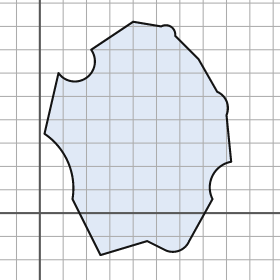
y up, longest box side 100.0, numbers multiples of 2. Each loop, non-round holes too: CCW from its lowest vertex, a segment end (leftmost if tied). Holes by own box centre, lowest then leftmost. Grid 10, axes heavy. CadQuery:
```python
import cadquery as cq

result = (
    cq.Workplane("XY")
    .moveTo(26.0, -18.0)
    .lineTo(46.0, -12.0)
    .lineTo(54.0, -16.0)
    .threePointArc((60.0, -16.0), (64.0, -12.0))
    .lineTo(74.0, 6.0)
    .threePointArc((74.0, 16.0), (82.0, 22.0))
    .lineTo(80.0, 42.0)
    .threePointArc((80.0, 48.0), (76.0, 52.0))
    .lineTo(68.0, 66.0)
    .lineTo(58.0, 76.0)
    .threePointArc((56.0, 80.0), (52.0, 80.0))
    .lineTo(40.0, 82.0)
    .lineTo(22.0, 70.0)
    .threePointArc((20.0, 58.0), (8.0, 60.0))
    .lineTo(2.0, 34.0)
    .threePointArc((12.0, 22.0), (14.0, 6.0))
    .close()
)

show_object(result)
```